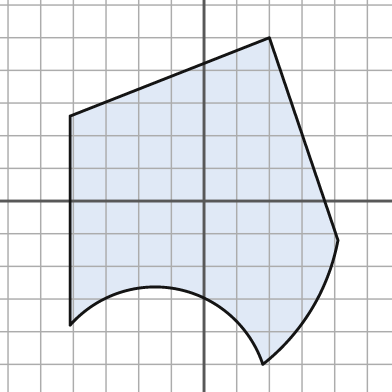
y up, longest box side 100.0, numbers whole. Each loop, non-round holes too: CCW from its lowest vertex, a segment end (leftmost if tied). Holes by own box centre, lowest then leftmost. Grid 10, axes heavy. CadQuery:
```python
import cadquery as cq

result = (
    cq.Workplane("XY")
    .moveTo(18.0, -50.0)
    .threePointArc((33.0, -33.0), (41.0, -12.0))
    .lineTo(20.0, 50.0)
    .lineTo(-41.0, 26.0)
    .lineTo(-41.0, -38.0)
    .threePointArc((-8.0, -27.0), (18.0, -50.0))
    .close()
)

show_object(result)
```